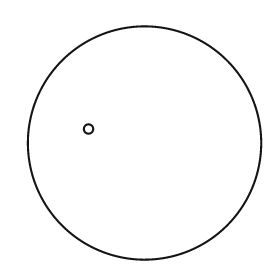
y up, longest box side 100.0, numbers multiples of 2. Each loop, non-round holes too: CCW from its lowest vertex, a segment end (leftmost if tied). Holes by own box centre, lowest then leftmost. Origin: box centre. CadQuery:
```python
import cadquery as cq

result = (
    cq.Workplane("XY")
    .moveTo(0.0, 0.0)
    .circle(50.0)
    .moveTo(-24.0, 6.0)
    .circle(2.0)
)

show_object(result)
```